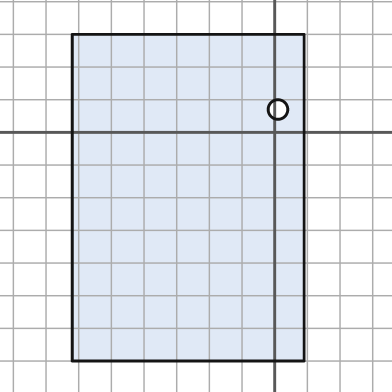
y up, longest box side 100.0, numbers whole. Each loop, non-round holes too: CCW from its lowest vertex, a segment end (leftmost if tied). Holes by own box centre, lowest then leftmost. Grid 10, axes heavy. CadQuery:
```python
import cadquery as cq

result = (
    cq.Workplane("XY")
    .moveTo(-62.0, -70.0)
    .lineTo(9.0, -70.0)
    .lineTo(9.0, 30.0)
    .lineTo(-62.0, 30.0)
    .close()
    .moveTo(1.0, 7.0)
    .circle(3.0)
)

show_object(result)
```